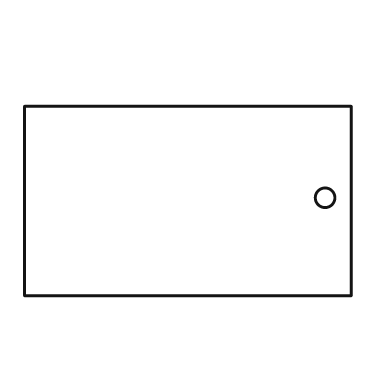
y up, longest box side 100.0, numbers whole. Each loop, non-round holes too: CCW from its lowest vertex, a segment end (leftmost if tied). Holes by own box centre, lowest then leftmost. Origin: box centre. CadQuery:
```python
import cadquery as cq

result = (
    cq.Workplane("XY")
    .moveTo(-50.0, -29.0)
    .lineTo(50.0, -29.0)
    .lineTo(50.0, 29.0)
    .lineTo(-50.0, 29.0)
    .close()
    .moveTo(42.0, 1.0)
    .circle(3.0)
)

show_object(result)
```